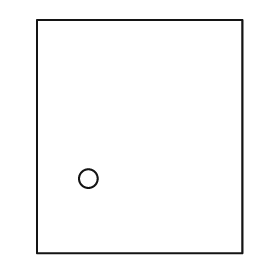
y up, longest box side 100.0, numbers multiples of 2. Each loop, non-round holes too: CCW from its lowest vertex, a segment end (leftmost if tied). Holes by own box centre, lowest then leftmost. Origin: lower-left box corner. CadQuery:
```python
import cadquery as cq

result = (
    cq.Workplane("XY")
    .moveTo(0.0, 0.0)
    .lineTo(88.0, 0.0)
    .lineTo(88.0, 100.0)
    .lineTo(0.0, 100.0)
    .close()
    .moveTo(22.0, 32.0)
    .circle(4.0)
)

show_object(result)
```